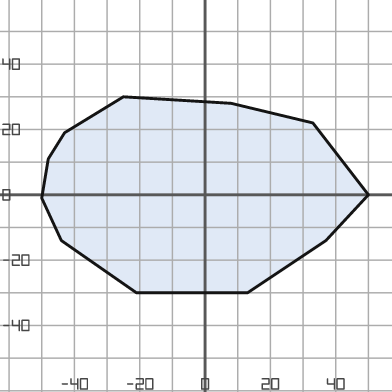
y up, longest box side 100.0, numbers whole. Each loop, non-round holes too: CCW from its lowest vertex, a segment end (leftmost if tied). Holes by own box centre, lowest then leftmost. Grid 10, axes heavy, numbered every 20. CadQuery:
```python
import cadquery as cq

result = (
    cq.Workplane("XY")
    .moveTo(-21.0, -30.0)
    .lineTo(13.0, -30.0)
    .lineTo(37.0, -14.0)
    .lineTo(50.0, 0.0)
    .lineTo(33.0, 22.0)
    .lineTo(8.0, 28.0)
    .lineTo(-25.0, 30.0)
    .lineTo(-43.0, 19.0)
    .lineTo(-48.0, 11.0)
    .lineTo(-50.0, -1.0)
    .lineTo(-44.0, -14.0)
    .close()
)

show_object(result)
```